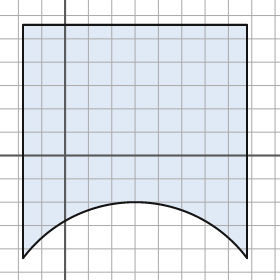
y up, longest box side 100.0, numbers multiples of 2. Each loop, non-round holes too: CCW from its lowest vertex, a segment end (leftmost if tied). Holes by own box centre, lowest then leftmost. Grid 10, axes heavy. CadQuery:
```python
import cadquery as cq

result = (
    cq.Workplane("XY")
    .moveTo(-18.0, -44.0)
    .threePointArc((30.0, -20.0), (78.0, -44.0))
    .lineTo(78.0, 56.0)
    .lineTo(-18.0, 56.0)
    .close()
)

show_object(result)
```